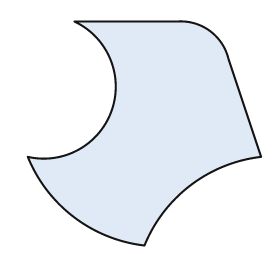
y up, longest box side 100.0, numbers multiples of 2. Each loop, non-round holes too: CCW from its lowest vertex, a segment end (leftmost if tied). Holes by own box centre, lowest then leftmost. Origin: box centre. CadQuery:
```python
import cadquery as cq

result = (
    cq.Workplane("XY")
    .moveTo(0.0, -48.0)
    .threePointArc((20.0, -22.0), (50.0, -10.0))
    .lineTo(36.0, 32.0)
    .threePointArc((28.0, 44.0), (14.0, 48.0))
    .lineTo(-30.0, 48.0)
    .threePointArc((-14.0, 10.0), (-50.0, -10.0))
    .threePointArc((-30.0, -36.0), (0.0, -48.0))
    .close()
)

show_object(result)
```